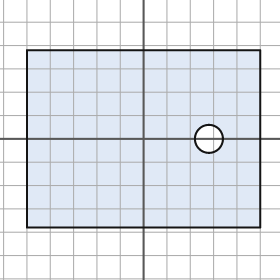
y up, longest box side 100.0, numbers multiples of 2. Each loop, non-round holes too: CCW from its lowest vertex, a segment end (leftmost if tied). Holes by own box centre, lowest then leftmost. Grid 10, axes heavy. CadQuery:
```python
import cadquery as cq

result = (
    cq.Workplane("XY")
    .moveTo(-50.0, -38.0)
    .lineTo(50.0, -38.0)
    .lineTo(50.0, 38.0)
    .lineTo(-50.0, 38.0)
    .close()
    .moveTo(28.0, 0.0)
    .circle(6.0)
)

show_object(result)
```